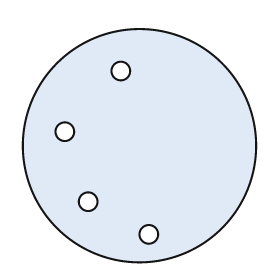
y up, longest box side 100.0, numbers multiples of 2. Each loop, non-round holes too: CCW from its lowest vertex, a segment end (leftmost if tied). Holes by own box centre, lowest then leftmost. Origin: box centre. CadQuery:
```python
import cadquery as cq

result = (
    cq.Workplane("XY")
    .moveTo(0.0, 0.0)
    .circle(50.0)
    .moveTo(4.0, -38.0)
    .circle(4.0)
    .moveTo(-22.0, -24.0)
    .circle(4.0)
    .moveTo(-32.0, 6.0)
    .circle(4.0)
    .moveTo(-8.0, 32.0)
    .circle(4.0)
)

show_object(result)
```